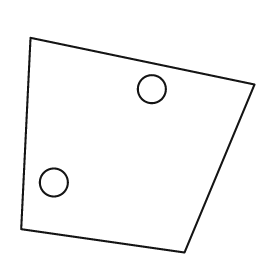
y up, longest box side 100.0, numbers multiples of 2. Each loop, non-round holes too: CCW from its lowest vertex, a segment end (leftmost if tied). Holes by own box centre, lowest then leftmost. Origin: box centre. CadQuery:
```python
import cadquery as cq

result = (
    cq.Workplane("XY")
    .moveTo(20.0, -46.0)
    .lineTo(50.0, 26.0)
    .lineTo(-46.0, 46.0)
    .lineTo(-50.0, -36.0)
    .close()
    .moveTo(-36.0, -16.0)
    .circle(6.0)
    .moveTo(6.0, 24.0)
    .circle(6.0)
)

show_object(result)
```